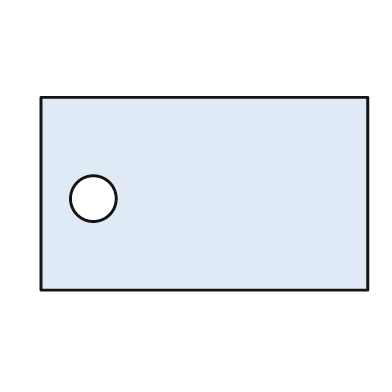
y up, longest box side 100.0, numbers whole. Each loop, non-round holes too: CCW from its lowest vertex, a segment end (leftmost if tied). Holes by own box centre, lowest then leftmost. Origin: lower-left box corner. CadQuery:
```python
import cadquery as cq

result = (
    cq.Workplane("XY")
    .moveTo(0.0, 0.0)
    .lineTo(100.0, 0.0)
    .lineTo(100.0, 59.0)
    .lineTo(0.0, 59.0)
    .close()
    .moveTo(16.0, 28.0)
    .circle(7.0)
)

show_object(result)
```